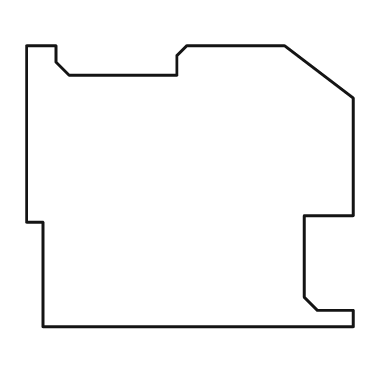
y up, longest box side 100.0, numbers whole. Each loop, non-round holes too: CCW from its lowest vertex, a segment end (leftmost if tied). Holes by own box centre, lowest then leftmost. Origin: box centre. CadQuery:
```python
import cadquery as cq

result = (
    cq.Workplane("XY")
    .moveTo(-45.0, -43.0)
    .lineTo(50.0, -43.0)
    .lineTo(50.0, -38.0)
    .lineTo(39.0, -38.0)
    .lineTo(35.0, -34.0)
    .lineTo(35.0, -9.0)
    .lineTo(50.0, -9.0)
    .lineTo(50.0, 27.0)
    .lineTo(29.0, 43.0)
    .lineTo(-1.0, 43.0)
    .lineTo(-4.0, 40.0)
    .lineTo(-4.0, 34.0)
    .lineTo(-37.0, 34.0)
    .lineTo(-41.0, 38.0)
    .lineTo(-41.0, 43.0)
    .lineTo(-50.0, 43.0)
    .lineTo(-50.0, -11.0)
    .lineTo(-45.0, -11.0)
    .close()
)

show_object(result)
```